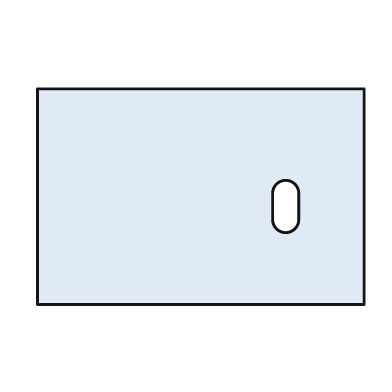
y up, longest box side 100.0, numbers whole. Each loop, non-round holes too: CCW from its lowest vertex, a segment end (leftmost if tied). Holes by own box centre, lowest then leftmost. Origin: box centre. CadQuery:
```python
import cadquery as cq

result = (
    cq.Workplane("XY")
    .moveTo(-50.0, -33.0)
    .lineTo(50.0, -33.0)
    .lineTo(50.0, 33.0)
    .lineTo(-50.0, 33.0)
    .close()
    .moveTo(22.0, -7.0)
    .threePointArc((26.0, -11.0), (30.0, -7.0))
    .lineTo(30.0, 1.0)
    .threePointArc((26.0, 5.0), (22.0, 1.0))
    .close()
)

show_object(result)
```